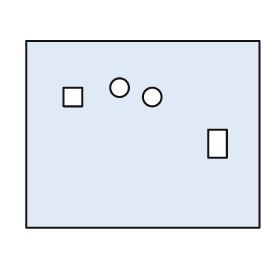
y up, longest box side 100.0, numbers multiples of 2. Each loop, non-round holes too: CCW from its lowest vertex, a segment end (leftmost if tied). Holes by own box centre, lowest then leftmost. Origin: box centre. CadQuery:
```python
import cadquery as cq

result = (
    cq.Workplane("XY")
    .moveTo(-50.0, -40.0)
    .lineTo(50.0, -40.0)
    .lineTo(50.0, 40.0)
    .lineTo(-50.0, 40.0)
    .close()
    .moveTo(28.0, -10.0)
    .lineTo(36.0, -10.0)
    .lineTo(36.0, 2.0)
    .lineTo(28.0, 2.0)
    .close()
    .moveTo(-34.0, 12.0)
    .lineTo(-26.0, 12.0)
    .lineTo(-26.0, 20.0)
    .lineTo(-34.0, 20.0)
    .close()
    .moveTo(4.0, 16.0)
    .circle(4.0)
    .moveTo(-10.0, 20.0)
    .circle(4.0)
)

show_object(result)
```